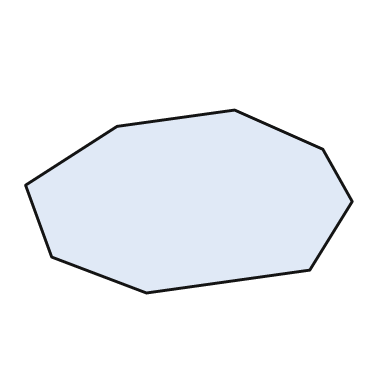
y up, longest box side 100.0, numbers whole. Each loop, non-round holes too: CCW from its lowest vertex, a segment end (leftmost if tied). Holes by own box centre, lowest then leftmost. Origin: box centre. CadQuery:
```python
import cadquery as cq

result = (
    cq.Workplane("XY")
    .moveTo(-13.0, -28.0)
    .lineTo(37.0, -21.0)
    .lineTo(50.0, 0.0)
    .lineTo(41.0, 16.0)
    .lineTo(14.0, 28.0)
    .lineTo(-22.0, 23.0)
    .lineTo(-50.0, 5.0)
    .lineTo(-42.0, -17.0)
    .close()
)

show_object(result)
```